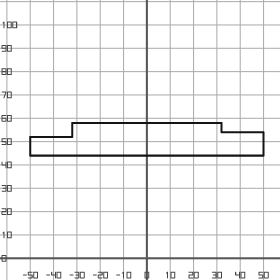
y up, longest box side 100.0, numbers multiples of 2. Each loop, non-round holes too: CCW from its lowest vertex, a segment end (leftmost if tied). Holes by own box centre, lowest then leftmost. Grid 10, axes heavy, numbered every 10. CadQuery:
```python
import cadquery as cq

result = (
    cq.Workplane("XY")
    .moveTo(-50.0, 44.0)
    .lineTo(50.0, 44.0)
    .lineTo(50.0, 54.0)
    .lineTo(32.0, 54.0)
    .lineTo(32.0, 58.0)
    .lineTo(-32.0, 58.0)
    .lineTo(-32.0, 52.0)
    .lineTo(-50.0, 52.0)
    .close()
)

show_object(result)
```